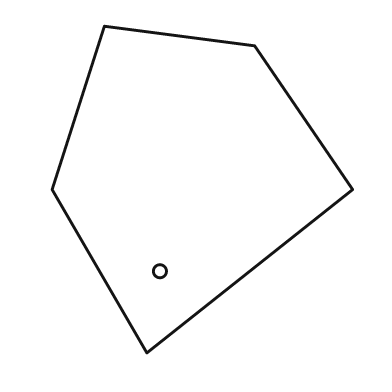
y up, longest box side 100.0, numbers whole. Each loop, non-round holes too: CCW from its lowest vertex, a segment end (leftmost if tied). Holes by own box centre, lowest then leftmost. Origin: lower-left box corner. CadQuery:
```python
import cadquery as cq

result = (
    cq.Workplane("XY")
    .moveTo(29.0, 0.0)
    .lineTo(92.0, 50.0)
    .lineTo(62.0, 94.0)
    .lineTo(16.0, 100.0)
    .lineTo(0.0, 50.0)
    .close()
    .moveTo(33.0, 25.0)
    .circle(2.0)
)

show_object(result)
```